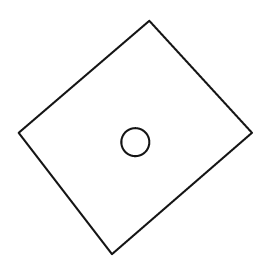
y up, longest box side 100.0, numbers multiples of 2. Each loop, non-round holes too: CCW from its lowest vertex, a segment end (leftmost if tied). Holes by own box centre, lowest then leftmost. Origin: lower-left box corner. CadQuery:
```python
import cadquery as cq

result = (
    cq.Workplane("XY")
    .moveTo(40.0, 0.0)
    .lineTo(100.0, 52.0)
    .lineTo(56.0, 100.0)
    .lineTo(0.0, 52.0)
    .close()
    .moveTo(50.0, 48.0)
    .circle(6.0)
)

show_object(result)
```